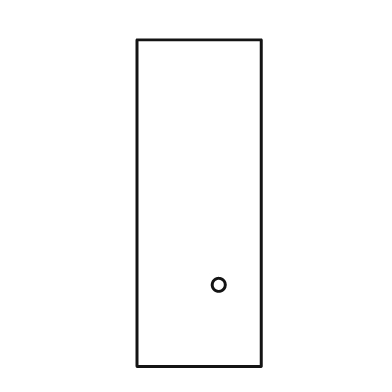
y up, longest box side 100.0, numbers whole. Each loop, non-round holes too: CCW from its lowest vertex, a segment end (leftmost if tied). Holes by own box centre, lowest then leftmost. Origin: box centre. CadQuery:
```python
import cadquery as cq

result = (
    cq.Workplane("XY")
    .moveTo(-19.0, -50.0)
    .lineTo(19.0, -50.0)
    .lineTo(19.0, 50.0)
    .lineTo(-19.0, 50.0)
    .close()
    .moveTo(6.0, -25.0)
    .circle(2.0)
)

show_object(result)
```